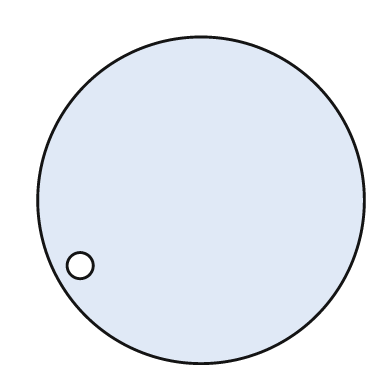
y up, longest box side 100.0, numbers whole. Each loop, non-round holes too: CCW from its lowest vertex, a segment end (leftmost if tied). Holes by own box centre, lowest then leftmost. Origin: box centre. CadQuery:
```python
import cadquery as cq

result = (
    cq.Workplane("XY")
    .moveTo(0.0, 0.0)
    .circle(50.0)
    .moveTo(-37.0, -20.0)
    .circle(4.0)
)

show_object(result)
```